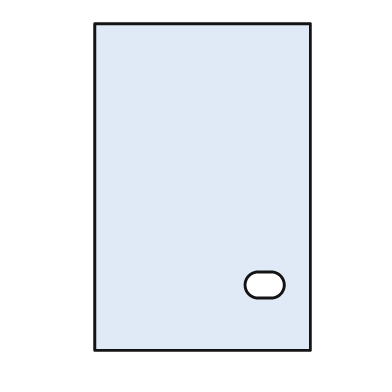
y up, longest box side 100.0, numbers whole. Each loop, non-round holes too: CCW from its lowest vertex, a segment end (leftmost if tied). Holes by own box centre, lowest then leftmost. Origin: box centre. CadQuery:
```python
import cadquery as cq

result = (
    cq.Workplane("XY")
    .moveTo(-33.0, -50.0)
    .lineTo(33.0, -50.0)
    .lineTo(33.0, 50.0)
    .lineTo(-33.0, 50.0)
    .close()
    .moveTo(17.0, -34.0)
    .lineTo(21.0, -34.0)
    .threePointArc((25.0, -30.0), (21.0, -26.0))
    .lineTo(17.0, -26.0)
    .threePointArc((13.0, -30.0), (17.0, -34.0))
    .close()
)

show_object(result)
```